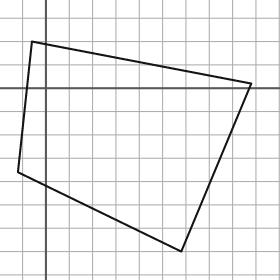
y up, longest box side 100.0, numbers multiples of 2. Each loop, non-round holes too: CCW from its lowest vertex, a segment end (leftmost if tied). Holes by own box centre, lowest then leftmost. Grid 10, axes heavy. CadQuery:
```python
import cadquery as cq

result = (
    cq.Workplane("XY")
    .moveTo(58.0, -70.0)
    .lineTo(88.0, 2.0)
    .lineTo(-6.0, 20.0)
    .lineTo(-12.0, -36.0)
    .close()
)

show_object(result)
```